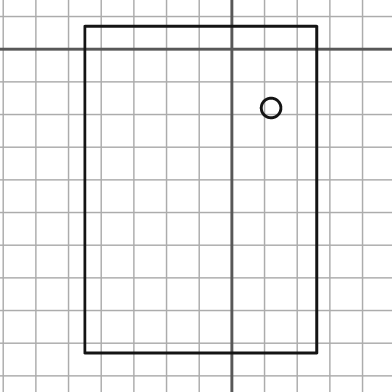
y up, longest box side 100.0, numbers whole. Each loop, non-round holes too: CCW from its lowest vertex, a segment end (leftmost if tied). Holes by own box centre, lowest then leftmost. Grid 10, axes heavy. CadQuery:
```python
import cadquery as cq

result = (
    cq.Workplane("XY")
    .moveTo(-45.0, -93.0)
    .lineTo(26.0, -93.0)
    .lineTo(26.0, 7.0)
    .lineTo(-45.0, 7.0)
    .close()
    .moveTo(12.0, -18.0)
    .circle(3.0)
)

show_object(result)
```